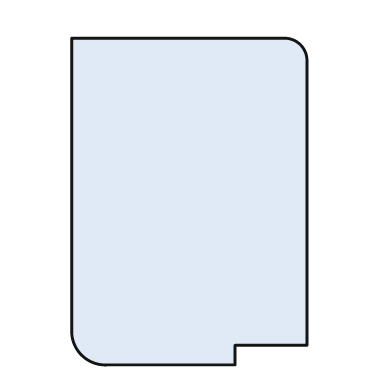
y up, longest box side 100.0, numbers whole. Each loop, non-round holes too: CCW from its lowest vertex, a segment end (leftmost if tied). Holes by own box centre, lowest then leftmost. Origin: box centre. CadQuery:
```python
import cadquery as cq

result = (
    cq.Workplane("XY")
    .moveTo(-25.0, -50.0)
    .lineTo(14.0, -50.0)
    .lineTo(14.0, -44.0)
    .lineTo(36.0, -44.0)
    .lineTo(36.0, 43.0)
    .threePointArc((34.0, 48.0), (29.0, 50.0))
    .lineTo(-36.0, 50.0)
    .lineTo(-36.0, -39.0)
    .threePointArc((-33.0, -47.0), (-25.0, -50.0))
    .close()
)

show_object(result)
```